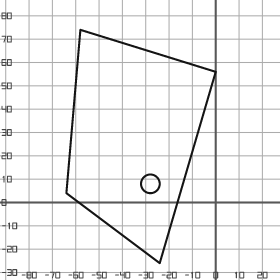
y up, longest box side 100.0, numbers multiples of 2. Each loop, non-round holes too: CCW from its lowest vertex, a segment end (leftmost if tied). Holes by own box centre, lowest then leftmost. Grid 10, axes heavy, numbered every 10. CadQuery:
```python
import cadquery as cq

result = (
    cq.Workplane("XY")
    .moveTo(-24.0, -26.0)
    .lineTo(0.0, 56.0)
    .lineTo(-58.0, 74.0)
    .lineTo(-64.0, 4.0)
    .close()
    .moveTo(-28.0, 8.0)
    .circle(4.0)
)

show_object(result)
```